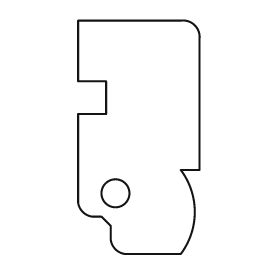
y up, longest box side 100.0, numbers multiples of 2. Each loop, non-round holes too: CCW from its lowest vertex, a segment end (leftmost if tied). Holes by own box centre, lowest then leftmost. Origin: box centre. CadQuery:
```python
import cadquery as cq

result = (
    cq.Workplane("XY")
    .moveTo(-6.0, -50.0)
    .lineTo(18.0, -50.0)
    .threePointArc((24.0, -32.0), (18.0, -14.0))
    .lineTo(26.0, -14.0)
    .lineTo(26.0, 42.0)
    .threePointArc((24.0, 48.0), (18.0, 50.0))
    .lineTo(-26.0, 50.0)
    .lineTo(-26.0, 24.0)
    .lineTo(-14.0, 24.0)
    .lineTo(-14.0, 10.0)
    .lineTo(-26.0, 10.0)
    .lineTo(-26.0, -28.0)
    .threePointArc((-24.0, -32.0), (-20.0, -34.0))
    .lineTo(-16.0, -34.0)
    .lineTo(-12.0, -38.0)
    .lineTo(-12.0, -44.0)
    .threePointArc((-10.0, -48.0), (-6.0, -50.0))
    .close()
    .moveTo(-10.0, -24.0)
    .circle(6.0)
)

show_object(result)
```